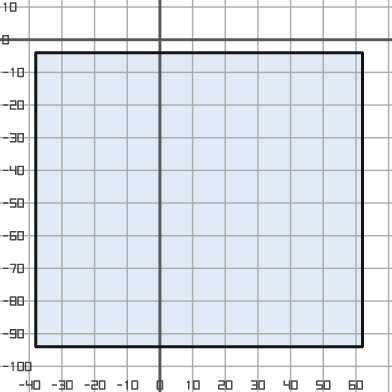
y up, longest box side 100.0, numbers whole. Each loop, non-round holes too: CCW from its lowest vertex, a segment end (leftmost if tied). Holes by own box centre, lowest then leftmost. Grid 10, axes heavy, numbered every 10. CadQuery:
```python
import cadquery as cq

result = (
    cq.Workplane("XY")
    .moveTo(-38.0, -94.0)
    .lineTo(62.0, -94.0)
    .lineTo(62.0, -4.0)
    .lineTo(-38.0, -4.0)
    .close()
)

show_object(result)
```